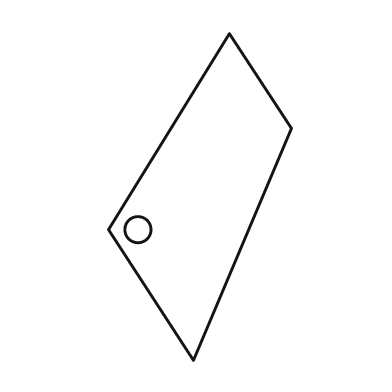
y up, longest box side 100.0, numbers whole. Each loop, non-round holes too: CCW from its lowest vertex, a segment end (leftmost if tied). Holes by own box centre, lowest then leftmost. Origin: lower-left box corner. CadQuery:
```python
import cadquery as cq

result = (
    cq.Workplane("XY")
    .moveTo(26.0, 0.0)
    .lineTo(56.0, 71.0)
    .lineTo(37.0, 100.0)
    .lineTo(0.0, 40.0)
    .close()
    .moveTo(9.0, 40.0)
    .circle(4.0)
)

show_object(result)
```